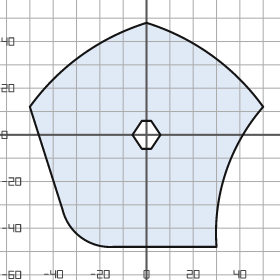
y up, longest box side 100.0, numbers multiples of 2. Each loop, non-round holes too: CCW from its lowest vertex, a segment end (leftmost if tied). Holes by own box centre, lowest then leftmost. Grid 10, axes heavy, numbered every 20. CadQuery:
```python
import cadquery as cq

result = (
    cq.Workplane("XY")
    .moveTo(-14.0, -48.0)
    .lineTo(30.0, -48.0)
    .threePointArc((34.0, -16.0), (50.0, 12.0))
    .threePointArc((28.0, 34.0), (0.0, 48.0))
    .threePointArc((-28.0, 34.0), (-50.0, 12.0))
    .lineTo(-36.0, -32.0)
    .threePointArc((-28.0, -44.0), (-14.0, -48.0))
    .close()
    .moveTo(-2.0, -6.0)
    .lineTo(2.0, -6.0)
    .lineTo(6.0, 0.0)
    .lineTo(2.0, 6.0)
    .lineTo(-2.0, 6.0)
    .lineTo(-6.0, 0.0)
    .close()
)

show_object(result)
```